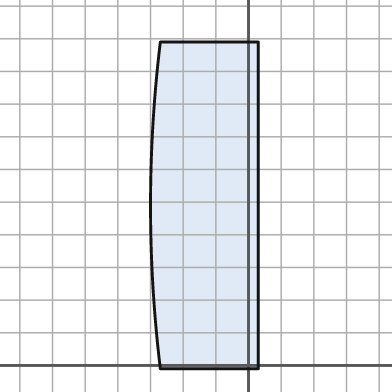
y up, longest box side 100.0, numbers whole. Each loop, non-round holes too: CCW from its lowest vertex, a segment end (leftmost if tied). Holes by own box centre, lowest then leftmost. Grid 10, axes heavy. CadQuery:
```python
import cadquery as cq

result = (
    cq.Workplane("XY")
    .moveTo(-27.0, -1.0)
    .lineTo(3.0, -1.0)
    .lineTo(3.0, 99.0)
    .lineTo(-27.0, 99.0)
    .threePointArc((-30.0, 49.0), (-27.0, -1.0))
    .close()
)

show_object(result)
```